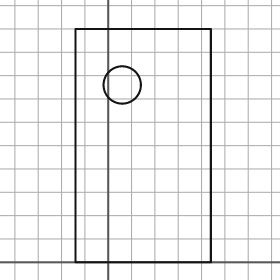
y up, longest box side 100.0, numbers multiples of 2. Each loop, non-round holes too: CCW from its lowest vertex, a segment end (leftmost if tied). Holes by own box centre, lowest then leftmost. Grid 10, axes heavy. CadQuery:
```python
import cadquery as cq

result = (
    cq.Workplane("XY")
    .moveTo(-14.0, 0.0)
    .lineTo(44.0, 0.0)
    .lineTo(44.0, 100.0)
    .lineTo(-14.0, 100.0)
    .close()
    .moveTo(6.0, 76.0)
    .circle(8.0)
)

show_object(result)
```